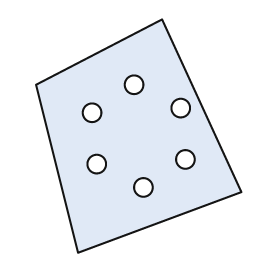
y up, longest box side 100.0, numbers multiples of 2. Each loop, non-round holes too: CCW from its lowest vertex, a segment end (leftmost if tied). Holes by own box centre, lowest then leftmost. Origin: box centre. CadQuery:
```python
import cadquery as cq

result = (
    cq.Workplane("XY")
    .moveTo(-26.0, -50.0)
    .lineTo(44.0, -24.0)
    .lineTo(10.0, 50.0)
    .lineTo(-44.0, 22.0)
    .close()
    .moveTo(2.0, -22.0)
    .circle(4.0)
    .moveTo(-18.0, -12.0)
    .circle(4.0)
    .moveTo(20.0, -10.0)
    .circle(4.0)
    .moveTo(-20.0, 10.0)
    .circle(4.0)
    .moveTo(18.0, 12.0)
    .circle(4.0)
    .moveTo(-2.0, 22.0)
    .circle(4.0)
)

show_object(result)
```